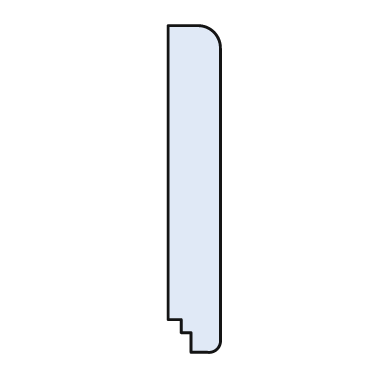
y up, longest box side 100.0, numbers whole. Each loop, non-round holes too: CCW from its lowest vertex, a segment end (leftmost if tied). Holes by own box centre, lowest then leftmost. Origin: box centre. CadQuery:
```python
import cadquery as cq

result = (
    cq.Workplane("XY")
    .moveTo(-1.0, -50.0)
    .lineTo(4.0, -50.0)
    .threePointArc((7.0, -49.0), (8.0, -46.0))
    .lineTo(8.0, 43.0)
    .threePointArc((6.0, 48.0), (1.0, 50.0))
    .lineTo(-8.0, 50.0)
    .lineTo(-8.0, -40.0)
    .lineTo(-4.0, -40.0)
    .lineTo(-4.0, -44.0)
    .lineTo(-1.0, -44.0)
    .close()
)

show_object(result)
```